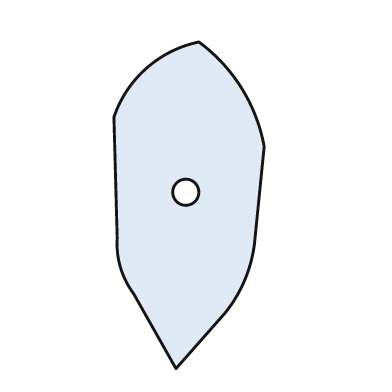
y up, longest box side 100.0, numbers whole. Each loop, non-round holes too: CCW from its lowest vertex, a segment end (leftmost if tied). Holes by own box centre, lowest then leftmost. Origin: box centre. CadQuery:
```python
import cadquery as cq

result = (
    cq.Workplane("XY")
    .moveTo(-4.0, -50.0)
    .lineTo(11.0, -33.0)
    .threePointArc((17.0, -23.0), (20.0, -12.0))
    .lineTo(23.0, 18.0)
    .threePointArc((16.0, 36.0), (3.0, 50.0))
    .threePointArc((-13.0, 42.0), (-23.0, 27.0))
    .lineTo(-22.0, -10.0)
    .threePointArc((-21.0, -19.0), (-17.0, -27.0))
    .close()
    .moveTo(-1.0, 4.0)
    .circle(4.0)
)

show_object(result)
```